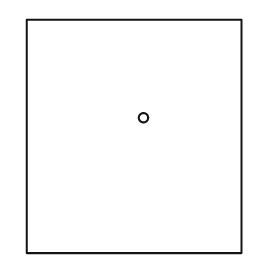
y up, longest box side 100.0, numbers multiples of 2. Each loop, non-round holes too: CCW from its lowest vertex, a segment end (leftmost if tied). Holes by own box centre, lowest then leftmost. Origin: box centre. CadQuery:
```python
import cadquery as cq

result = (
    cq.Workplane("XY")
    .moveTo(-46.0, -50.0)
    .lineTo(46.0, -50.0)
    .lineTo(46.0, 50.0)
    .lineTo(-46.0, 50.0)
    .close()
    .moveTo(4.0, 8.0)
    .circle(2.0)
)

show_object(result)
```